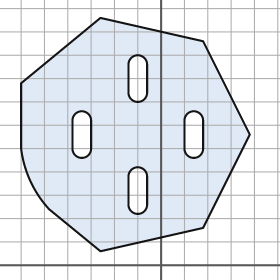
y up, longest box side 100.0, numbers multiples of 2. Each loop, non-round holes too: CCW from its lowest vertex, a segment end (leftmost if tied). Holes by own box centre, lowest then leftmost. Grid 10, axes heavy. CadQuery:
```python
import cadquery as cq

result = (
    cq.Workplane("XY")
    .moveTo(-26.0, 6.0)
    .lineTo(18.0, 16.0)
    .lineTo(38.0, 56.0)
    .lineTo(18.0, 96.0)
    .lineTo(-26.0, 106.0)
    .lineTo(-60.0, 78.0)
    .lineTo(-60.0, 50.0)
    .threePointArc((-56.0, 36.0), (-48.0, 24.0))
    .close()
    .moveTo(-14.0, 26.0)
    .threePointArc((-10.0, 22.0), (-6.0, 26.0))
    .lineTo(-6.0, 38.0)
    .threePointArc((-10.0, 42.0), (-14.0, 38.0))
    .close()
    .moveTo(-38.0, 50.0)
    .threePointArc((-34.0, 46.0), (-30.0, 50.0))
    .lineTo(-30.0, 62.0)
    .threePointArc((-34.0, 66.0), (-38.0, 62.0))
    .close()
    .moveTo(10.0, 50.0)
    .threePointArc((14.0, 46.0), (18.0, 50.0))
    .lineTo(18.0, 62.0)
    .threePointArc((14.0, 66.0), (10.0, 62.0))
    .close()
    .moveTo(-14.0, 74.0)
    .threePointArc((-10.0, 70.0), (-6.0, 74.0))
    .lineTo(-6.0, 86.0)
    .threePointArc((-10.0, 90.0), (-14.0, 86.0))
    .close()
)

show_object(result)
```